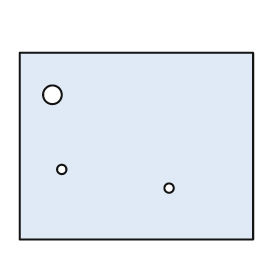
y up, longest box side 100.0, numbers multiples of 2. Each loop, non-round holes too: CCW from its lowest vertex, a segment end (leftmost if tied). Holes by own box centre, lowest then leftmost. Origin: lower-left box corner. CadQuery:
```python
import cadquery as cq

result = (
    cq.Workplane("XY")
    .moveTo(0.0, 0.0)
    .lineTo(100.0, 0.0)
    .lineTo(100.0, 80.0)
    .lineTo(0.0, 80.0)
    .close()
    .moveTo(64.0, 22.0)
    .circle(2.0)
    .moveTo(18.0, 30.0)
    .circle(2.0)
    .moveTo(14.0, 62.0)
    .circle(4.0)
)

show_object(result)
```